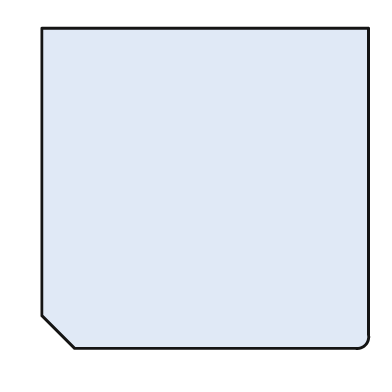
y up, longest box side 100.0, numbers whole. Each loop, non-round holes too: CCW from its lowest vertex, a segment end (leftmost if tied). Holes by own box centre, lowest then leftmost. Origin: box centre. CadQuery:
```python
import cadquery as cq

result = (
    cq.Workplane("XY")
    .moveTo(-40.0, -49.0)
    .lineTo(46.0, -49.0)
    .threePointArc((49.0, -48.0), (50.0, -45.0))
    .lineTo(50.0, 49.0)
    .lineTo(-50.0, 49.0)
    .lineTo(-50.0, -39.0)
    .close()
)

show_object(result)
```